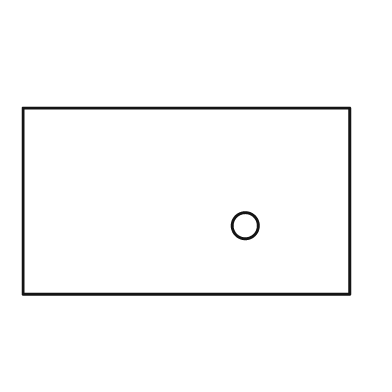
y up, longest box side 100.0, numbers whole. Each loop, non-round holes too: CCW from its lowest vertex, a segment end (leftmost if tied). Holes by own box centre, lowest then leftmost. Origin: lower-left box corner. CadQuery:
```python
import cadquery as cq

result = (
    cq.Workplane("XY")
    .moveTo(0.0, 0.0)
    .lineTo(100.0, 0.0)
    .lineTo(100.0, 57.0)
    .lineTo(0.0, 57.0)
    .close()
    .moveTo(68.0, 21.0)
    .circle(4.0)
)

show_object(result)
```